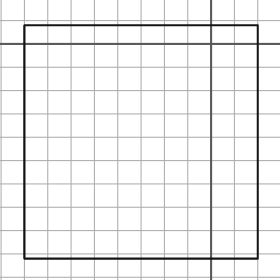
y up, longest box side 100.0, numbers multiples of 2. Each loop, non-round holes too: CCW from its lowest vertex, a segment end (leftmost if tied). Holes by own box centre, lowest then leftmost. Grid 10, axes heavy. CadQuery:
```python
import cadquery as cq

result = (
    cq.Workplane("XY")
    .moveTo(-80.0, -92.0)
    .lineTo(20.0, -92.0)
    .lineTo(20.0, 8.0)
    .lineTo(-80.0, 8.0)
    .close()
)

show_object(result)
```